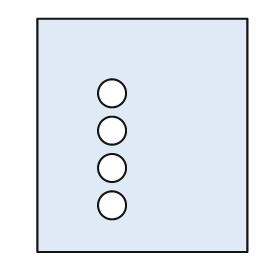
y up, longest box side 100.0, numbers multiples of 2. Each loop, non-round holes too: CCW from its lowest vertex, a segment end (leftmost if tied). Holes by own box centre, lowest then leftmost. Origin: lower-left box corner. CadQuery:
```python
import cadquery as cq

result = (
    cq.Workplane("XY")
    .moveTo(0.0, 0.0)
    .lineTo(90.0, 0.0)
    .lineTo(90.0, 100.0)
    .lineTo(0.0, 100.0)
    .close()
    .moveTo(32.0, 20.0)
    .circle(6.0)
    .moveTo(32.0, 36.0)
    .circle(6.0)
    .moveTo(32.0, 52.0)
    .circle(6.0)
    .moveTo(32.0, 68.0)
    .circle(6.0)
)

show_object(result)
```